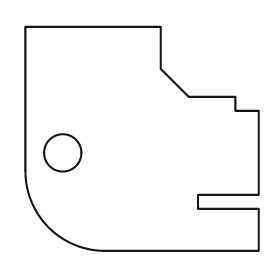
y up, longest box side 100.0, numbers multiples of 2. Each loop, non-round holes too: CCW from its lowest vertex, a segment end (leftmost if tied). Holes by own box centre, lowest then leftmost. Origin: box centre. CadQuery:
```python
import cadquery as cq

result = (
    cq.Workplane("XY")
    .moveTo(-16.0, -48.0)
    .lineTo(50.0, -48.0)
    .lineTo(50.0, -30.0)
    .lineTo(24.0, -30.0)
    .lineTo(24.0, -24.0)
    .lineTo(50.0, -24.0)
    .lineTo(50.0, 12.0)
    .lineTo(40.0, 12.0)
    .lineTo(40.0, 18.0)
    .lineTo(20.0, 18.0)
    .lineTo(8.0, 30.0)
    .lineTo(8.0, 48.0)
    .lineTo(-50.0, 48.0)
    .lineTo(-50.0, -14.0)
    .threePointArc((-40.0, -38.0), (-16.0, -48.0))
    .close()
    .moveTo(-34.0, -6.0)
    .circle(8.0)
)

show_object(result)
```